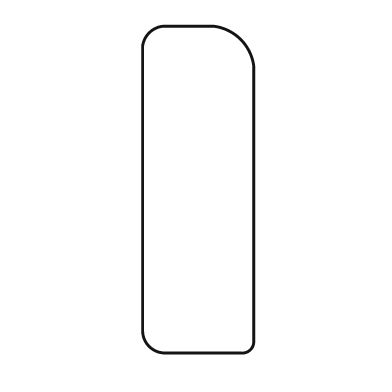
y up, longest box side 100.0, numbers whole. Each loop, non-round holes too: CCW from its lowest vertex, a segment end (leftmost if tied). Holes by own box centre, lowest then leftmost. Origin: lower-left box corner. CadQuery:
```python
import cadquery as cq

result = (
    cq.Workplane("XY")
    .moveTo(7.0, 0.0)
    .lineTo(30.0, 0.0)
    .threePointArc((33.0, 1.0), (34.0, 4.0))
    .lineTo(34.0, 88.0)
    .threePointArc((30.0, 96.0), (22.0, 100.0))
    .lineTo(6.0, 100.0)
    .threePointArc((2.0, 98.0), (0.0, 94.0))
    .lineTo(0.0, 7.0)
    .threePointArc((2.0, 2.0), (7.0, 0.0))
    .close()
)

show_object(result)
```